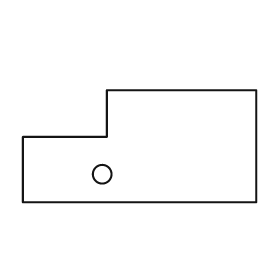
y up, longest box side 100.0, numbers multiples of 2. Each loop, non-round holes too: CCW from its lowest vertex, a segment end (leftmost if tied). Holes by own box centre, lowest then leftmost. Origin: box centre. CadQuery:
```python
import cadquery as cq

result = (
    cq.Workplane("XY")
    .moveTo(-50.0, -24.0)
    .lineTo(50.0, -24.0)
    .lineTo(50.0, 24.0)
    .lineTo(-14.0, 24.0)
    .lineTo(-14.0, 4.0)
    .lineTo(-50.0, 4.0)
    .close()
    .moveTo(-16.0, -12.0)
    .circle(4.0)
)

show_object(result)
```